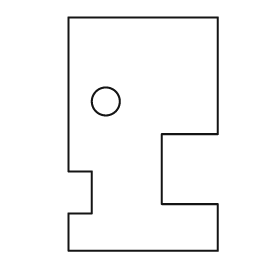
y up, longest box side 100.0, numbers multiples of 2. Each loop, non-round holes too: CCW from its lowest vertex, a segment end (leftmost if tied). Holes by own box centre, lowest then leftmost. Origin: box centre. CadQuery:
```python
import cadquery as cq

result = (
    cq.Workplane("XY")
    .moveTo(-32.0, -50.0)
    .lineTo(32.0, -50.0)
    .lineTo(32.0, -30.0)
    .lineTo(8.0, -30.0)
    .lineTo(8.0, 0.0)
    .lineTo(32.0, 0.0)
    .lineTo(32.0, 50.0)
    .lineTo(-32.0, 50.0)
    .lineTo(-32.0, -16.0)
    .lineTo(-22.0, -16.0)
    .lineTo(-22.0, -34.0)
    .lineTo(-32.0, -34.0)
    .close()
    .moveTo(-16.0, 14.0)
    .circle(6.0)
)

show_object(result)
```